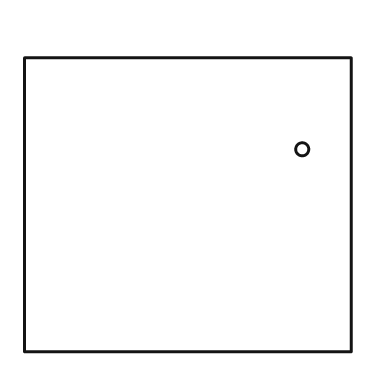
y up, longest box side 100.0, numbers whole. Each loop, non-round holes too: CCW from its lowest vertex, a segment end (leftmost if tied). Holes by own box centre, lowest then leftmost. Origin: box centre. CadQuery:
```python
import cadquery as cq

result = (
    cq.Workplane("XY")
    .moveTo(-50.0, -45.0)
    .lineTo(50.0, -45.0)
    .lineTo(50.0, 45.0)
    .lineTo(-50.0, 45.0)
    .close()
    .moveTo(35.0, 17.0)
    .circle(2.0)
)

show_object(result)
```